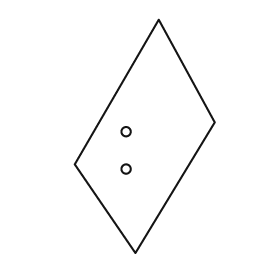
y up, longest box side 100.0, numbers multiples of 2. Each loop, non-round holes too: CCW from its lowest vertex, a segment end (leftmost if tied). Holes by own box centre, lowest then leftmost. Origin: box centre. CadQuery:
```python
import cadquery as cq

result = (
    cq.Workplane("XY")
    .moveTo(-4.0, -50.0)
    .lineTo(30.0, 6.0)
    .lineTo(6.0, 50.0)
    .lineTo(-30.0, -12.0)
    .close()
    .moveTo(-8.0, -14.0)
    .circle(2.0)
    .moveTo(-8.0, 2.0)
    .circle(2.0)
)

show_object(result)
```